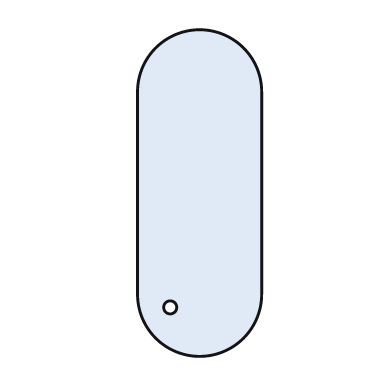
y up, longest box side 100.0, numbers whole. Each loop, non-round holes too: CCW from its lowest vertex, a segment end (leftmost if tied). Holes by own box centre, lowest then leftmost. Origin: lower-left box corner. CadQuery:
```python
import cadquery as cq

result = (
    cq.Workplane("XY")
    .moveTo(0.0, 19.0)
    .threePointArc((19.0, 0.0), (38.0, 19.0))
    .lineTo(38.0, 81.0)
    .threePointArc((19.0, 100.0), (0.0, 81.0))
    .close()
    .moveTo(10.0, 15.0)
    .circle(2.0)
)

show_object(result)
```